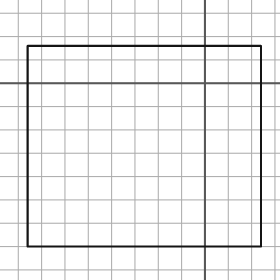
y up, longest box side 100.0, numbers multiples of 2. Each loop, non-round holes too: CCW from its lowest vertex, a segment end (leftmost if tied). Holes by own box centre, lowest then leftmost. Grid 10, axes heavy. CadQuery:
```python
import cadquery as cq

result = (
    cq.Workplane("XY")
    .moveTo(-76.0, -70.0)
    .lineTo(24.0, -70.0)
    .lineTo(24.0, 16.0)
    .lineTo(-76.0, 16.0)
    .close()
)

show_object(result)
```